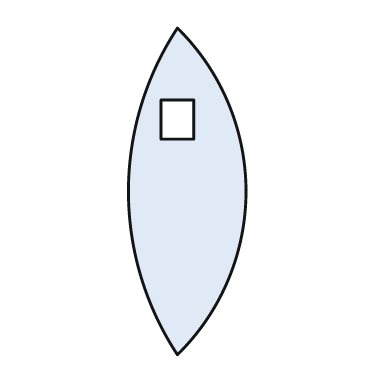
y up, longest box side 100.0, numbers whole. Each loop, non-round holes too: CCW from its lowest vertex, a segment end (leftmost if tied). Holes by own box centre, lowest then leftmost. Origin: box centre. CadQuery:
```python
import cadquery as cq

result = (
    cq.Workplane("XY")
    .moveTo(-3.0, -50.0)
    .threePointArc((18.0, 0.0), (-3.0, 50.0))
    .threePointArc((-18.0, 0.0), (-3.0, -50.0))
    .close()
    .moveTo(-8.0, 16.0)
    .lineTo(2.0, 16.0)
    .lineTo(2.0, 28.0)
    .lineTo(-8.0, 28.0)
    .close()
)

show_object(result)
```